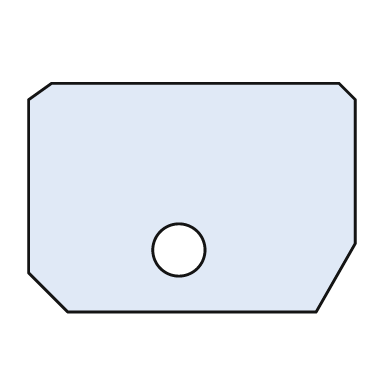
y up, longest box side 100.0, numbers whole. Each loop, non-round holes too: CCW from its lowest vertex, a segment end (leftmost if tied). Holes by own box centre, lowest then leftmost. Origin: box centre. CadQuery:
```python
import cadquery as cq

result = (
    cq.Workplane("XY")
    .moveTo(-38.0, -35.0)
    .lineTo(38.0, -35.0)
    .lineTo(50.0, -14.0)
    .lineTo(50.0, 30.0)
    .lineTo(45.0, 35.0)
    .lineTo(-43.0, 35.0)
    .lineTo(-50.0, 30.0)
    .lineTo(-50.0, -23.0)
    .close()
    .moveTo(-4.0, -16.0)
    .circle(8.0)
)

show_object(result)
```